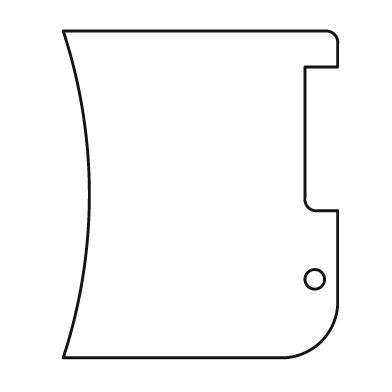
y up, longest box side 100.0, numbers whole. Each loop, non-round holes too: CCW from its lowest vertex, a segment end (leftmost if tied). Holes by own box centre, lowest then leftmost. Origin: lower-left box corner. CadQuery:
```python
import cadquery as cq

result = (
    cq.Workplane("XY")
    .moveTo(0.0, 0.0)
    .lineTo(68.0, 0.0)
    .threePointArc((79.0, 5.0), (84.0, 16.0))
    .lineTo(84.0, 45.0)
    .lineTo(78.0, 45.0)
    .threePointArc((75.0, 46.0), (74.0, 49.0))
    .lineTo(74.0, 89.0)
    .lineTo(84.0, 89.0)
    .lineTo(84.0, 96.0)
    .threePointArc((83.0, 99.0), (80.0, 100.0))
    .lineTo(0.0, 100.0)
    .threePointArc((8.0, 50.0), (0.0, 0.0))
    .close()
    .moveTo(77.0, 24.0)
    .circle(3.0)
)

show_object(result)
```